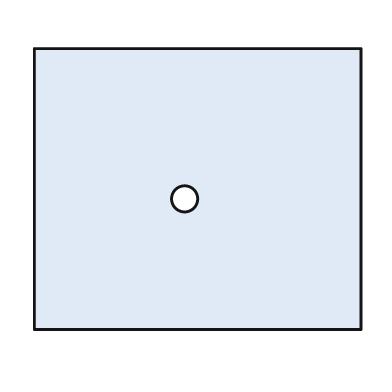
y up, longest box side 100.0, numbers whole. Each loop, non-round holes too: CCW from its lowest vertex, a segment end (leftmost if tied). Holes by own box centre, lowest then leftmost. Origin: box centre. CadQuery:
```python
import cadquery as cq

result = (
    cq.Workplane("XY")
    .moveTo(-50.0, -43.0)
    .lineTo(50.0, -43.0)
    .lineTo(50.0, 43.0)
    .lineTo(-50.0, 43.0)
    .close()
    .moveTo(-4.0, -3.0)
    .circle(4.0)
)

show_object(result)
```